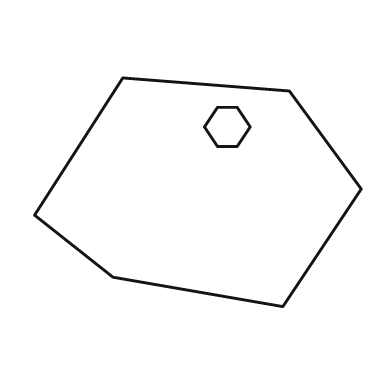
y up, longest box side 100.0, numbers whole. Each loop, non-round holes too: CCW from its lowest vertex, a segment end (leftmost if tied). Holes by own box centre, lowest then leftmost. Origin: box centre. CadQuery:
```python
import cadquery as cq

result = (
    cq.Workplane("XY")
    .moveTo(26.0, -35.0)
    .lineTo(50.0, 1.0)
    .lineTo(28.0, 31.0)
    .lineTo(-23.0, 35.0)
    .lineTo(-50.0, -7.0)
    .lineTo(-26.0, -26.0)
    .close()
    .moveTo(6.0, 14.0)
    .lineTo(12.0, 14.0)
    .lineTo(16.0, 20.0)
    .lineTo(12.0, 26.0)
    .lineTo(6.0, 26.0)
    .lineTo(2.0, 20.0)
    .close()
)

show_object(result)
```